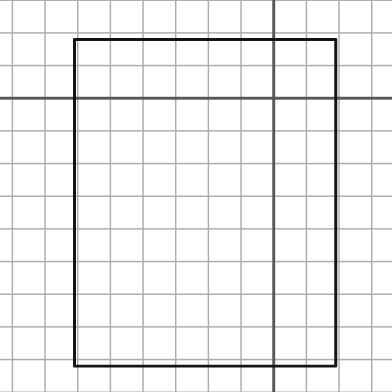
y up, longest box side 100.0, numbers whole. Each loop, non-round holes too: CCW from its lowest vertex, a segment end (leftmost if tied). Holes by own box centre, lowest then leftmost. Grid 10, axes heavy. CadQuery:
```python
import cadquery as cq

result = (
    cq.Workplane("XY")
    .moveTo(-61.0, -82.0)
    .lineTo(19.0, -82.0)
    .lineTo(19.0, 18.0)
    .lineTo(-61.0, 18.0)
    .close()
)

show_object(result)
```